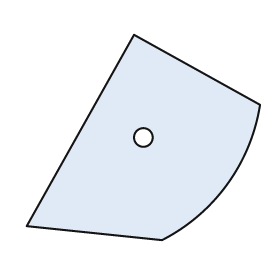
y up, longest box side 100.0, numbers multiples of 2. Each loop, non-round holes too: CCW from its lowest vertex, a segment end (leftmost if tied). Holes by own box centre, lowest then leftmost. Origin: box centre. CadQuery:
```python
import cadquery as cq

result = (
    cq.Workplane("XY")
    .moveTo(8.0, -44.0)
    .threePointArc((36.0, -20.0), (50.0, 14.0))
    .lineTo(-4.0, 44.0)
    .lineTo(-50.0, -38.0)
    .close()
    .moveTo(0.0, 0.0)
    .circle(4.0)
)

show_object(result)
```